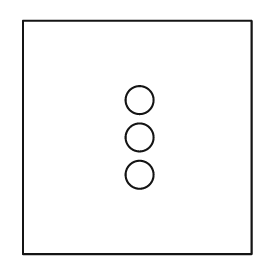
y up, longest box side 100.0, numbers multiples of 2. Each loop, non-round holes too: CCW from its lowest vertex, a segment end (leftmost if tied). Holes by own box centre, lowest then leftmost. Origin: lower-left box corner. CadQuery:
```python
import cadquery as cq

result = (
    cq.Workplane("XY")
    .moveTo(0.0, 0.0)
    .lineTo(98.0, 0.0)
    .lineTo(98.0, 100.0)
    .lineTo(0.0, 100.0)
    .close()
    .moveTo(50.0, 34.0)
    .circle(6.0)
    .moveTo(50.0, 50.0)
    .circle(6.0)
    .moveTo(50.0, 66.0)
    .circle(6.0)
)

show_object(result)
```